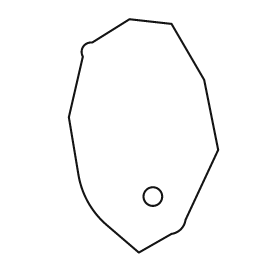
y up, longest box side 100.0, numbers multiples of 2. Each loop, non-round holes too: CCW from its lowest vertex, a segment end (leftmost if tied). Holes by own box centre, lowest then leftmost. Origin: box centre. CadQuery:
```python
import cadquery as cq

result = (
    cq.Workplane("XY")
    .moveTo(-2.0, -50.0)
    .lineTo(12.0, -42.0)
    .threePointArc((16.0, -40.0), (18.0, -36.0))
    .lineTo(32.0, -6.0)
    .lineTo(26.0, 24.0)
    .lineTo(12.0, 48.0)
    .lineTo(-6.0, 50.0)
    .lineTo(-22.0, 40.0)
    .threePointArc((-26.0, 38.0), (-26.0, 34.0))
    .lineTo(-32.0, 8.0)
    .lineTo(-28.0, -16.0)
    .threePointArc((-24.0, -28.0), (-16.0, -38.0))
    .close()
    .moveTo(4.0, -26.0)
    .circle(4.0)
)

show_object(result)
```